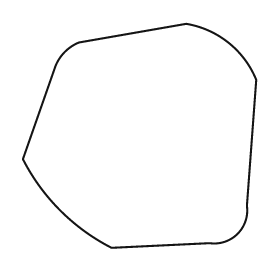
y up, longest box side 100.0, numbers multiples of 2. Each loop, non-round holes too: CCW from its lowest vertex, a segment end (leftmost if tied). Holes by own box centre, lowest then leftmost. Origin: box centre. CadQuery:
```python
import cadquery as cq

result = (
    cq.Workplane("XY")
    .moveTo(-12.0, -48.0)
    .lineTo(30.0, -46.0)
    .threePointArc((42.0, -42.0), (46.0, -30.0))
    .lineTo(50.0, 24.0)
    .threePointArc((38.0, 40.0), (20.0, 48.0))
    .lineTo(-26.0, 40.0)
    .threePointArc((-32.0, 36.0), (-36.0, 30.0))
    .lineTo(-50.0, -10.0)
    .threePointArc((-34.0, -32.0), (-12.0, -48.0))
    .close()
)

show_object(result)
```